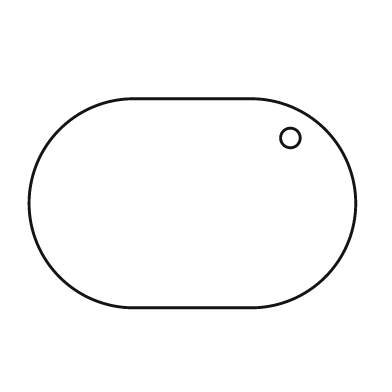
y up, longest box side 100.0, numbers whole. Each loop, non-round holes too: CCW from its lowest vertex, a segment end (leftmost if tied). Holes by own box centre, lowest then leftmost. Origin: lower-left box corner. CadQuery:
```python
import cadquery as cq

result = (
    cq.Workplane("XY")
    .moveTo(32.0, 0.0)
    .lineTo(68.0, 0.0)
    .threePointArc((100.0, 32.0), (68.0, 64.0))
    .lineTo(32.0, 64.0)
    .threePointArc((0.0, 32.0), (32.0, 0.0))
    .close()
    .moveTo(80.0, 52.0)
    .circle(3.0)
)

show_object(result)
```